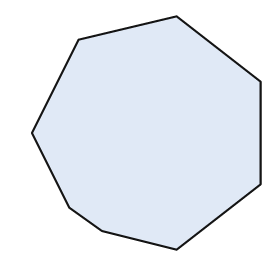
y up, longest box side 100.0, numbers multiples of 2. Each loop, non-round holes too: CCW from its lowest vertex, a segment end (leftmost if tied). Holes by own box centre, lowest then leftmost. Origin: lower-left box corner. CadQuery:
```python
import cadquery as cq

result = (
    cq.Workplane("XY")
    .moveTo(62.0, 0.0)
    .lineTo(98.0, 28.0)
    .lineTo(98.0, 72.0)
    .lineTo(62.0, 100.0)
    .lineTo(20.0, 90.0)
    .lineTo(0.0, 50.0)
    .lineTo(16.0, 18.0)
    .lineTo(30.0, 8.0)
    .close()
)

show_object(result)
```